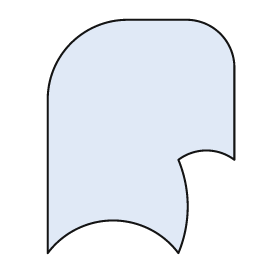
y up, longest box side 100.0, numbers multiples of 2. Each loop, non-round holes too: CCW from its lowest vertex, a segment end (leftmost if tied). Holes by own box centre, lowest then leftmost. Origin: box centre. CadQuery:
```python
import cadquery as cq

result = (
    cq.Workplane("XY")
    .moveTo(-40.0, -50.0)
    .threePointArc((-12.0, -36.0), (16.0, -50.0))
    .threePointArc((20.0, -30.0), (16.0, -10.0))
    .threePointArc((28.0, -6.0), (40.0, -10.0))
    .lineTo(40.0, 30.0)
    .threePointArc((34.0, 44.0), (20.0, 50.0))
    .lineTo(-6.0, 50.0)
    .threePointArc((-30.0, 40.0), (-40.0, 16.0))
    .close()
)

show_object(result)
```